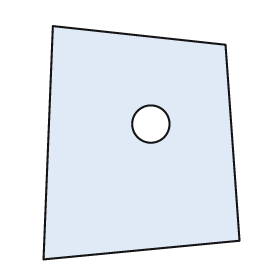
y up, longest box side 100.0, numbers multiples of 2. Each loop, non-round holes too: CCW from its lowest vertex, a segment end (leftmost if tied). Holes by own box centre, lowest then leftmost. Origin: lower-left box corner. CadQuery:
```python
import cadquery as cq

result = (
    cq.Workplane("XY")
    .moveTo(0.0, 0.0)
    .lineTo(84.0, 8.0)
    .lineTo(78.0, 92.0)
    .lineTo(4.0, 100.0)
    .close()
    .moveTo(46.0, 58.0)
    .circle(8.0)
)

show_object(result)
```